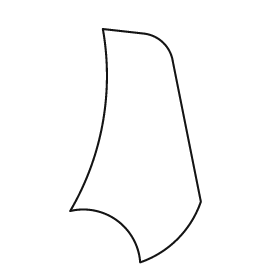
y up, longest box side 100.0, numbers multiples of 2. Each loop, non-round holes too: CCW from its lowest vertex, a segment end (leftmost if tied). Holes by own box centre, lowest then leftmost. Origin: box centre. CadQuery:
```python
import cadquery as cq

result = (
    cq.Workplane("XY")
    .moveTo(2.0, -50.0)
    .threePointArc((18.0, -40.0), (28.0, -24.0))
    .lineTo(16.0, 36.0)
    .threePointArc((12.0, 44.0), (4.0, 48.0))
    .lineTo(-14.0, 50.0)
    .threePointArc((-14.0, 10.0), (-28.0, -28.0))
    .threePointArc((-8.0, -32.0), (2.0, -50.0))
    .close()
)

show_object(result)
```